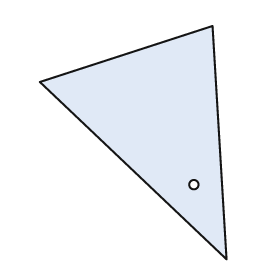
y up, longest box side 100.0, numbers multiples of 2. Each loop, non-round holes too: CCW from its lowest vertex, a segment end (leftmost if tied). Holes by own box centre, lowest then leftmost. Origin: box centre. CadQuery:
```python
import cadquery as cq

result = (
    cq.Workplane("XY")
    .moveTo(40.0, -50.0)
    .lineTo(34.0, 50.0)
    .lineTo(-40.0, 26.0)
    .close()
    .moveTo(26.0, -18.0)
    .circle(2.0)
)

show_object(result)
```